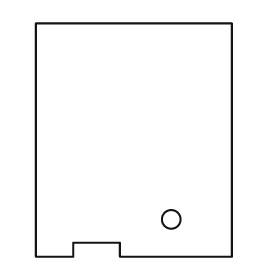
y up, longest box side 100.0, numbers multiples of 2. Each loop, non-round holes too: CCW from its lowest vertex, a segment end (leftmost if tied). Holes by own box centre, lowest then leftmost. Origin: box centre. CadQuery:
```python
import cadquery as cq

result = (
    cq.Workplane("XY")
    .moveTo(-42.0, -50.0)
    .lineTo(-26.0, -50.0)
    .lineTo(-26.0, -44.0)
    .lineTo(-6.0, -44.0)
    .lineTo(-6.0, -50.0)
    .lineTo(42.0, -50.0)
    .lineTo(42.0, 50.0)
    .lineTo(-42.0, 50.0)
    .close()
    .moveTo(16.0, -34.0)
    .circle(4.0)
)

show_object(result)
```